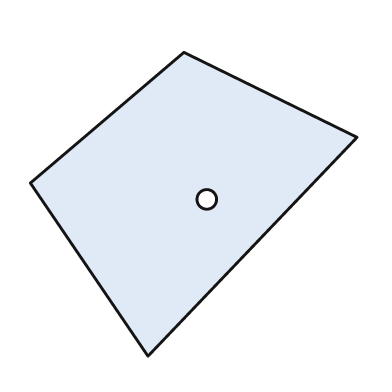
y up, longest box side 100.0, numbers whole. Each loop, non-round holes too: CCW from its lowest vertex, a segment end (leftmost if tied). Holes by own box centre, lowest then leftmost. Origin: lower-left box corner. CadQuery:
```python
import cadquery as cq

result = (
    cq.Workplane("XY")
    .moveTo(36.0, 0.0)
    .lineTo(100.0, 67.0)
    .lineTo(47.0, 93.0)
    .lineTo(0.0, 53.0)
    .close()
    .moveTo(54.0, 48.0)
    .circle(3.0)
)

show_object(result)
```